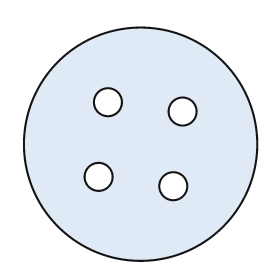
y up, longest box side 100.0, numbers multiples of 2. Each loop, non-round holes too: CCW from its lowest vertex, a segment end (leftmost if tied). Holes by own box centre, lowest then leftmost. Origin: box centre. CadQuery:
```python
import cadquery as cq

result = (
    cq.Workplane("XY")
    .moveTo(0.0, 0.0)
    .circle(50.0)
    .moveTo(14.0, -18.0)
    .circle(6.0)
    .moveTo(-18.0, -14.0)
    .circle(6.0)
    .moveTo(18.0, 14.0)
    .circle(6.0)
    .moveTo(-14.0, 18.0)
    .circle(6.0)
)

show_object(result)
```